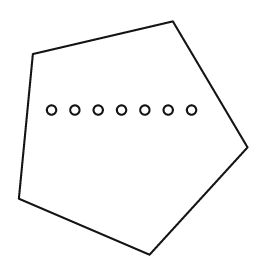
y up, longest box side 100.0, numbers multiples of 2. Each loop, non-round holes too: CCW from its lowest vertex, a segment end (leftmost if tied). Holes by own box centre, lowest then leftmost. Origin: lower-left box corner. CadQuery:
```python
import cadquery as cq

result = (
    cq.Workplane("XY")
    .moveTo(56.0, 0.0)
    .lineTo(98.0, 46.0)
    .lineTo(66.0, 100.0)
    .lineTo(6.0, 86.0)
    .lineTo(0.0, 24.0)
    .close()
    .moveTo(14.0, 62.0)
    .circle(2.0)
    .moveTo(24.0, 62.0)
    .circle(2.0)
    .moveTo(34.0, 62.0)
    .circle(2.0)
    .moveTo(44.0, 62.0)
    .circle(2.0)
    .moveTo(54.0, 62.0)
    .circle(2.0)
    .moveTo(64.0, 62.0)
    .circle(2.0)
    .moveTo(74.0, 62.0)
    .circle(2.0)
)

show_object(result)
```